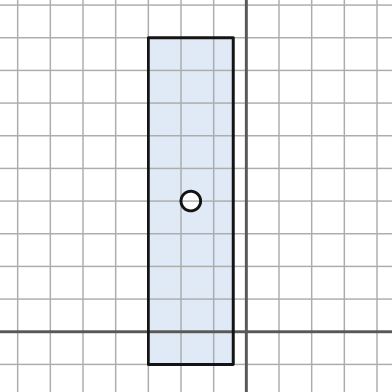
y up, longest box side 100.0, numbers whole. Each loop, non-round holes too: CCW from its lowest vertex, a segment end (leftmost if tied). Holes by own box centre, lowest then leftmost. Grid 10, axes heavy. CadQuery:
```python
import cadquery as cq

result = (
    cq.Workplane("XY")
    .moveTo(-30.0, -10.0)
    .lineTo(-4.0, -10.0)
    .lineTo(-4.0, 90.0)
    .lineTo(-30.0, 90.0)
    .close()
    .moveTo(-17.0, 40.0)
    .circle(3.0)
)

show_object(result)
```